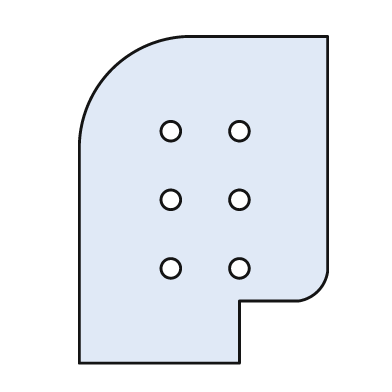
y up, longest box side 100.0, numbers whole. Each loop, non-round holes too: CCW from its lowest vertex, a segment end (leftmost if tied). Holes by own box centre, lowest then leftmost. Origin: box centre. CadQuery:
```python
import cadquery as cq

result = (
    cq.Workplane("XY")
    .moveTo(-38.0, -50.0)
    .lineTo(11.0, -50.0)
    .lineTo(11.0, -31.0)
    .lineTo(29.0, -31.0)
    .threePointArc((35.0, -28.0), (38.0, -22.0))
    .lineTo(38.0, 50.0)
    .lineTo(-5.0, 50.0)
    .threePointArc((-28.0, 40.0), (-38.0, 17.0))
    .close()
    .moveTo(-10.0, -21.0)
    .circle(3.0)
    .moveTo(11.0, -21.0)
    .circle(3.0)
    .moveTo(-10.0, 0.0)
    .circle(3.0)
    .moveTo(11.0, 0.0)
    .circle(3.0)
    .moveTo(-10.0, 21.0)
    .circle(3.0)
    .moveTo(11.0, 21.0)
    .circle(3.0)
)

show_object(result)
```